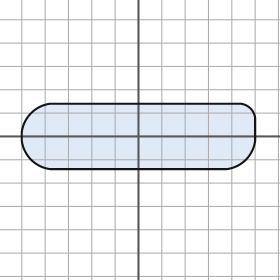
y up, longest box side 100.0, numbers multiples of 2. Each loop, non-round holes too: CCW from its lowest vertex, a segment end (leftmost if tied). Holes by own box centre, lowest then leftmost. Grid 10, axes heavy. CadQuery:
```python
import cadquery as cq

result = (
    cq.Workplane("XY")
    .moveTo(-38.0, -14.0)
    .lineTo(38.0, -14.0)
    .threePointArc((46.0, -10.0), (50.0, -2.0))
    .lineTo(50.0, 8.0)
    .threePointArc((48.0, 12.0), (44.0, 14.0))
    .lineTo(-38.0, 14.0)
    .threePointArc((-46.0, 10.0), (-50.0, 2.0))
    .lineTo(-50.0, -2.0)
    .threePointArc((-46.0, -10.0), (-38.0, -14.0))
    .close()
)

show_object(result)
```